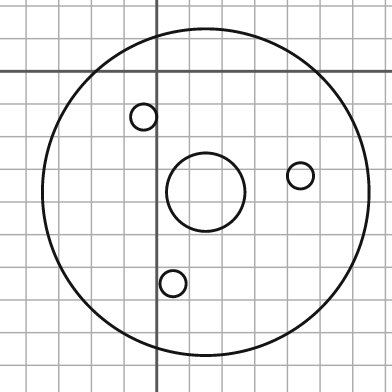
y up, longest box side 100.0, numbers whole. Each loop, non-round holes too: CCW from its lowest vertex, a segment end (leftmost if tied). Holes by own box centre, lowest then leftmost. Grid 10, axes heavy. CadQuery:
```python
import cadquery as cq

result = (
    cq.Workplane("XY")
    .moveTo(15.0, -37.0)
    .circle(50.0)
    .moveTo(5.0, -65.0)
    .circle(4.0)
    .moveTo(15.0, -37.0)
    .circle(12.0)
    .moveTo(44.0, -32.0)
    .circle(4.0)
    .moveTo(-4.0, -14.0)
    .circle(4.0)
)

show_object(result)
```